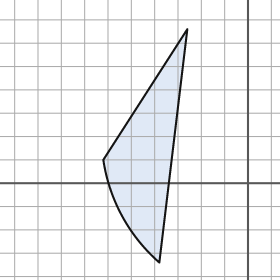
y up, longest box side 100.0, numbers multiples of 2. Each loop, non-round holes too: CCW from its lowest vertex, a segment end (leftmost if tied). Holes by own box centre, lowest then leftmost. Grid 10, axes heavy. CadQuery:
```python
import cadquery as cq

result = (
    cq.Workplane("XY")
    .moveTo(-38.0, -34.0)
    .lineTo(-26.0, 66.0)
    .lineTo(-62.0, 10.0)
    .threePointArc((-54.0, -14.0), (-38.0, -34.0))
    .close()
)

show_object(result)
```